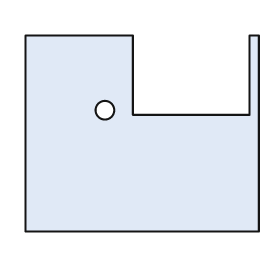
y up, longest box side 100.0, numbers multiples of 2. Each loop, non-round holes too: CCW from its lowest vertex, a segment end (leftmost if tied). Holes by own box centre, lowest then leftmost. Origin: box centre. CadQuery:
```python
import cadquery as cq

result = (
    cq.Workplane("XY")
    .moveTo(-50.0, -42.0)
    .lineTo(50.0, -42.0)
    .lineTo(50.0, 42.0)
    .lineTo(46.0, 42.0)
    .lineTo(46.0, 8.0)
    .lineTo(-4.0, 8.0)
    .lineTo(-4.0, 42.0)
    .lineTo(-50.0, 42.0)
    .close()
    .moveTo(-16.0, 10.0)
    .circle(4.0)
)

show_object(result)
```